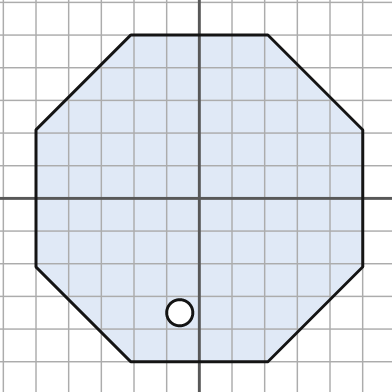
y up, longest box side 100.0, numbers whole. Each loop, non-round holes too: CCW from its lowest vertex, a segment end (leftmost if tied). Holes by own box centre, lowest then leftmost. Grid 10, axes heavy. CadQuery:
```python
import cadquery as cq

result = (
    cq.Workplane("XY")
    .moveTo(-21.0, -50.0)
    .lineTo(21.0, -50.0)
    .lineTo(50.0, -21.0)
    .lineTo(50.0, 21.0)
    .lineTo(21.0, 50.0)
    .lineTo(-21.0, 50.0)
    .lineTo(-50.0, 21.0)
    .lineTo(-50.0, -21.0)
    .close()
    .moveTo(-6.0, -35.0)
    .circle(4.0)
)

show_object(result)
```